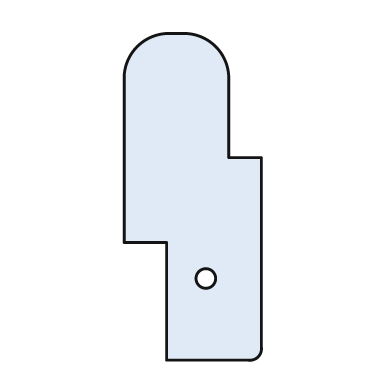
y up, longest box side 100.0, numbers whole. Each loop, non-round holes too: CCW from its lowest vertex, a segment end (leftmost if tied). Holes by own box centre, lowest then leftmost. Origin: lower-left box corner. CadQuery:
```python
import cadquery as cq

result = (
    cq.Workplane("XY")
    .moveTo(13.0, 0.0)
    .lineTo(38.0, 0.0)
    .threePointArc((41.0, 1.0), (42.0, 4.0))
    .lineTo(42.0, 62.0)
    .lineTo(32.0, 62.0)
    .lineTo(32.0, 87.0)
    .threePointArc((28.0, 96.0), (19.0, 100.0))
    .lineTo(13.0, 100.0)
    .threePointArc((4.0, 96.0), (0.0, 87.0))
    .lineTo(0.0, 36.0)
    .lineTo(13.0, 36.0)
    .close()
    .moveTo(25.0, 25.0)
    .circle(3.0)
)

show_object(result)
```